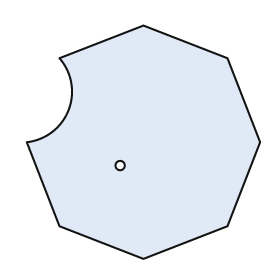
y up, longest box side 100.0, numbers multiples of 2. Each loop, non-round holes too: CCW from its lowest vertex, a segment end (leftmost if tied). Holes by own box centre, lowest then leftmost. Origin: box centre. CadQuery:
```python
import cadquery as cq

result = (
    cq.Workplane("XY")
    .moveTo(0.0, -50.0)
    .lineTo(36.0, -36.0)
    .lineTo(50.0, 0.0)
    .lineTo(36.0, 36.0)
    .lineTo(0.0, 50.0)
    .lineTo(-36.0, 36.0)
    .threePointArc((-32.0, 14.0), (-50.0, 0.0))
    .lineTo(-36.0, -36.0)
    .close()
    .moveTo(-10.0, -10.0)
    .circle(2.0)
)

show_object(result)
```